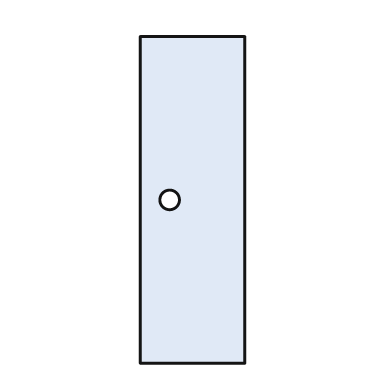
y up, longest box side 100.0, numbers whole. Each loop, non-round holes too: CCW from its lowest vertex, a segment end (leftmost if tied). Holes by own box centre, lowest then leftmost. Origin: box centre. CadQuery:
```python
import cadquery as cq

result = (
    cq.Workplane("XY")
    .moveTo(-16.0, -50.0)
    .lineTo(16.0, -50.0)
    .lineTo(16.0, 50.0)
    .lineTo(-16.0, 50.0)
    .close()
    .moveTo(-7.0, 0.0)
    .circle(3.0)
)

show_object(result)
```